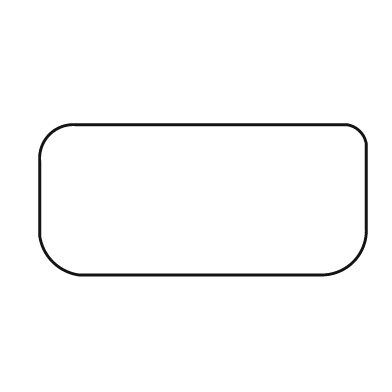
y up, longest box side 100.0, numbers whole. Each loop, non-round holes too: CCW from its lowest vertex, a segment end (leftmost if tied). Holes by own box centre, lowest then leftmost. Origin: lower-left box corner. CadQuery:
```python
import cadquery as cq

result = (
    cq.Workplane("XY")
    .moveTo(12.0, 0.0)
    .lineTo(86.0, 0.0)
    .threePointArc((96.0, 4.0), (100.0, 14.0))
    .lineTo(100.0, 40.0)
    .threePointArc((98.0, 44.0), (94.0, 46.0))
    .lineTo(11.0, 46.0)
    .threePointArc((3.0, 43.0), (0.0, 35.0))
    .lineTo(0.0, 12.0)
    .threePointArc((4.0, 4.0), (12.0, 0.0))
    .close()
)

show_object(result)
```